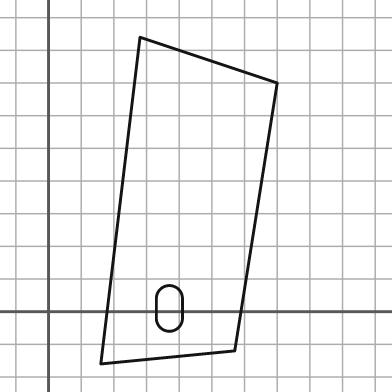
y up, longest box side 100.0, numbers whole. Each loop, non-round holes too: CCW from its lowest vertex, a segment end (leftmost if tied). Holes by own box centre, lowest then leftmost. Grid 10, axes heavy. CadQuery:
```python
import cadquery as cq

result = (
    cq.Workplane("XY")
    .moveTo(16.0, -16.0)
    .lineTo(57.0, -12.0)
    .lineTo(70.0, 70.0)
    .lineTo(28.0, 84.0)
    .close()
    .moveTo(33.0, -2.0)
    .threePointArc((37.0, -6.0), (41.0, -2.0))
    .lineTo(41.0, 4.0)
    .threePointArc((37.0, 8.0), (33.0, 4.0))
    .close()
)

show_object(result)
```